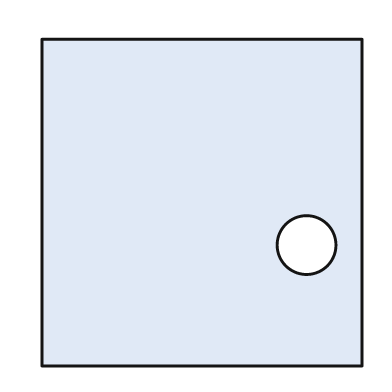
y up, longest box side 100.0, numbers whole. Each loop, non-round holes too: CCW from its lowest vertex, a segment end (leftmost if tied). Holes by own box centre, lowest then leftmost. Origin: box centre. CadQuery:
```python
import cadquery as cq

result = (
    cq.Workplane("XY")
    .moveTo(-49.0, -50.0)
    .lineTo(49.0, -50.0)
    .lineTo(49.0, 50.0)
    .lineTo(-49.0, 50.0)
    .close()
    .moveTo(32.0, -13.0)
    .circle(9.0)
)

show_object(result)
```